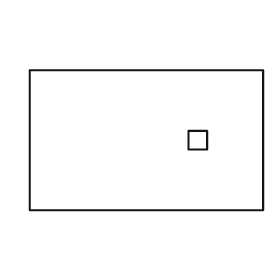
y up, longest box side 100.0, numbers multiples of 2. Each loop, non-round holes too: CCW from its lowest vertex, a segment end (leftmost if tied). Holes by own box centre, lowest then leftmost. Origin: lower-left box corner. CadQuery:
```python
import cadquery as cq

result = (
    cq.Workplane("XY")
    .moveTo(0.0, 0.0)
    .lineTo(100.0, 0.0)
    .lineTo(100.0, 60.0)
    .lineTo(0.0, 60.0)
    .close()
    .moveTo(68.0, 26.0)
    .lineTo(76.0, 26.0)
    .lineTo(76.0, 34.0)
    .lineTo(68.0, 34.0)
    .close()
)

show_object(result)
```